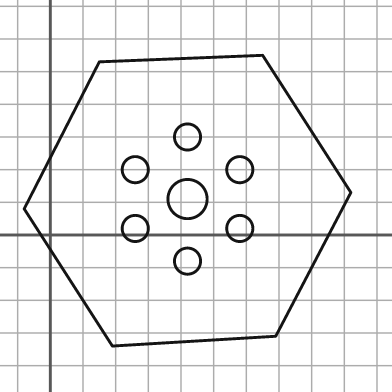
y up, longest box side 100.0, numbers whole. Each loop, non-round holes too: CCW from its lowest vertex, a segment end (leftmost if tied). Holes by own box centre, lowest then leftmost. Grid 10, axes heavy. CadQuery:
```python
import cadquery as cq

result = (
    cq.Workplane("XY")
    .moveTo(19.0, -34.0)
    .lineTo(69.0, -31.0)
    .lineTo(92.0, 13.0)
    .lineTo(65.0, 55.0)
    .lineTo(15.0, 53.0)
    .lineTo(-8.0, 8.0)
    .close()
    .moveTo(42.0, -8.0)
    .circle(4.0)
    .moveTo(26.0, 2.0)
    .circle(4.0)
    .moveTo(58.0, 2.0)
    .circle(4.0)
    .moveTo(42.0, 11.0)
    .circle(6.0)
    .moveTo(26.0, 20.0)
    .circle(4.0)
    .moveTo(58.0, 20.0)
    .circle(4.0)
    .moveTo(42.0, 30.0)
    .circle(4.0)
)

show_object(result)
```